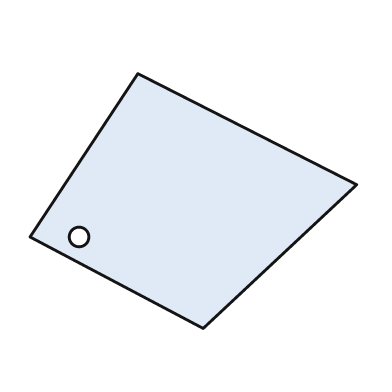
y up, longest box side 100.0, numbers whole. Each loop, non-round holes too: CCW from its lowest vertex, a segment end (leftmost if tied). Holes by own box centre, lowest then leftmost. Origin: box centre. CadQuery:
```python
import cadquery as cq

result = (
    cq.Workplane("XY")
    .moveTo(3.0, -39.0)
    .lineTo(50.0, 5.0)
    .lineTo(-17.0, 39.0)
    .lineTo(-50.0, -11.0)
    .close()
    .moveTo(-35.0, -11.0)
    .circle(3.0)
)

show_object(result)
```